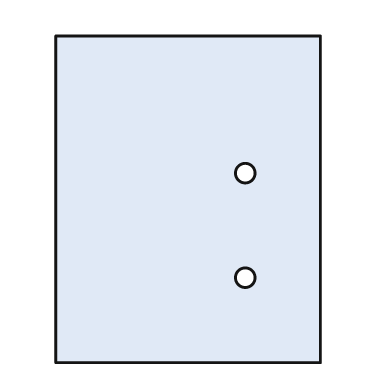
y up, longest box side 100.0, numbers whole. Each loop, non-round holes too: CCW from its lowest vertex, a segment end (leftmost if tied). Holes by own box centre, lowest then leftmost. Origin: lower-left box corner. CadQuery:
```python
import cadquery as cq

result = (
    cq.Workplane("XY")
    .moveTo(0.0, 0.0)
    .lineTo(81.0, 0.0)
    .lineTo(81.0, 100.0)
    .lineTo(0.0, 100.0)
    .close()
    .moveTo(58.0, 26.0)
    .circle(3.0)
    .moveTo(58.0, 58.0)
    .circle(3.0)
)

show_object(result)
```